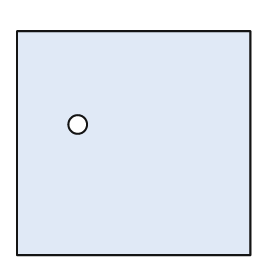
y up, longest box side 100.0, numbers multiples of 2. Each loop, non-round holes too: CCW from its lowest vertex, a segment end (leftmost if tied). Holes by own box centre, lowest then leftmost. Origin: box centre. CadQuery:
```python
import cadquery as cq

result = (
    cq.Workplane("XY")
    .moveTo(-50.0, -48.0)
    .lineTo(50.0, -48.0)
    .lineTo(50.0, 48.0)
    .lineTo(-50.0, 48.0)
    .close()
    .moveTo(-24.0, 8.0)
    .circle(4.0)
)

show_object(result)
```